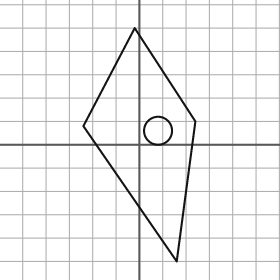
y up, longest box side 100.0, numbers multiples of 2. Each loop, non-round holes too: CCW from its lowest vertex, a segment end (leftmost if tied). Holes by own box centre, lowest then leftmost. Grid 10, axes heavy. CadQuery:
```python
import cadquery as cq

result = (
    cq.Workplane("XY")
    .moveTo(16.0, -50.0)
    .lineTo(24.0, 10.0)
    .lineTo(-2.0, 50.0)
    .lineTo(-24.0, 8.0)
    .close()
    .moveTo(8.0, 6.0)
    .circle(6.0)
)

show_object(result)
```